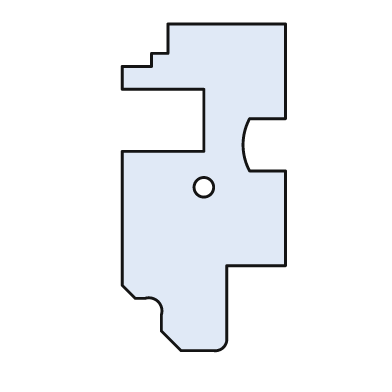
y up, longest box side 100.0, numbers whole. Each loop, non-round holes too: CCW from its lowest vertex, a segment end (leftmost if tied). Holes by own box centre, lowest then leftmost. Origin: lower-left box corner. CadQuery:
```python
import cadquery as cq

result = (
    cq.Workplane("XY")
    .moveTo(18.0, 0.0)
    .lineTo(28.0, 0.0)
    .threePointArc((31.0, 1.0), (32.0, 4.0))
    .lineTo(32.0, 26.0)
    .lineTo(50.0, 26.0)
    .lineTo(50.0, 55.0)
    .lineTo(39.0, 55.0)
    .threePointArc((37.0, 63.0), (39.0, 71.0))
    .lineTo(50.0, 71.0)
    .lineTo(50.0, 100.0)
    .lineTo(14.0, 100.0)
    .lineTo(14.0, 91.0)
    .lineTo(9.0, 91.0)
    .lineTo(9.0, 87.0)
    .lineTo(0.0, 87.0)
    .lineTo(0.0, 80.0)
    .lineTo(25.0, 80.0)
    .lineTo(25.0, 61.0)
    .lineTo(0.0, 61.0)
    .lineTo(0.0, 20.0)
    .lineTo(4.0, 16.0)
    .lineTo(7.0, 16.0)
    .threePointArc((11.0, 15.0), (12.0, 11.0))
    .lineTo(12.0, 6.0)
    .close()
    .moveTo(25.0, 50.0)
    .circle(3.0)
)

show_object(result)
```